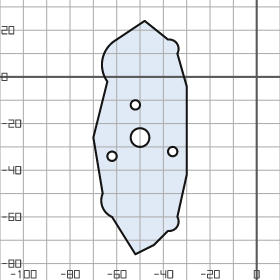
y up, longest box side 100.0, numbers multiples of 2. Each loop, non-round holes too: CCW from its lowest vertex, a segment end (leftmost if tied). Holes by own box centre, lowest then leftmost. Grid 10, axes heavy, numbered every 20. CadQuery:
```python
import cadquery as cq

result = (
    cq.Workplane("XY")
    .moveTo(-52.0, -76.0)
    .lineTo(-44.0, -72.0)
    .lineTo(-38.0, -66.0)
    .threePointArc((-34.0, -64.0), (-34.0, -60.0))
    .lineTo(-30.0, -42.0)
    .lineTo(-30.0, -4.0)
    .lineTo(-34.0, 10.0)
    .threePointArc((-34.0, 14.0), (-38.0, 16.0))
    .lineTo(-48.0, 24.0)
    .lineTo(-60.0, 16.0)
    .threePointArc((-66.0, 8.0), (-64.0, -2.0))
    .lineTo(-70.0, -26.0)
    .lineTo(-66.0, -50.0)
    .threePointArc((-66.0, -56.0), (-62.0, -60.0))
    .close()
    .moveTo(-62.0, -34.0)
    .circle(2.0)
    .moveTo(-36.0, -32.0)
    .circle(2.0)
    .moveTo(-50.0, -26.0)
    .circle(4.0)
    .moveTo(-52.0, -12.0)
    .circle(2.0)
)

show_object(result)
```